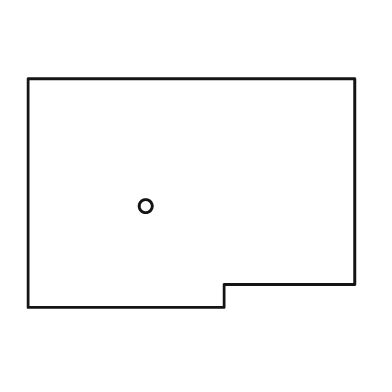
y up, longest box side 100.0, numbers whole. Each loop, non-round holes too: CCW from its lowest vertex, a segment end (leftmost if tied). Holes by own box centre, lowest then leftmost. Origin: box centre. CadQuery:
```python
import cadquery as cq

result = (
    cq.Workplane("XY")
    .moveTo(-50.0, -35.0)
    .lineTo(10.0, -35.0)
    .lineTo(10.0, -28.0)
    .lineTo(50.0, -28.0)
    .lineTo(50.0, 35.0)
    .lineTo(-50.0, 35.0)
    .close()
    .moveTo(-14.0, -4.0)
    .circle(2.0)
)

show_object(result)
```